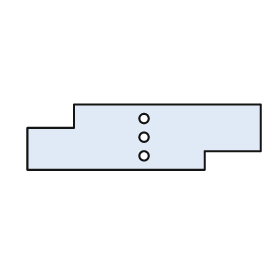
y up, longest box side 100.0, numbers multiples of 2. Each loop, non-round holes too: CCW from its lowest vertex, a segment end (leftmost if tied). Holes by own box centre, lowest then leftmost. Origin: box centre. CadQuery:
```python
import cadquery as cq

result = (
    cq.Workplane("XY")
    .moveTo(-50.0, -14.0)
    .lineTo(26.0, -14.0)
    .lineTo(26.0, -6.0)
    .lineTo(50.0, -6.0)
    .lineTo(50.0, 14.0)
    .lineTo(-30.0, 14.0)
    .lineTo(-30.0, 4.0)
    .lineTo(-50.0, 4.0)
    .close()
    .moveTo(0.0, -8.0)
    .circle(2.0)
    .moveTo(0.0, 0.0)
    .circle(2.0)
    .moveTo(0.0, 8.0)
    .circle(2.0)
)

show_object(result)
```